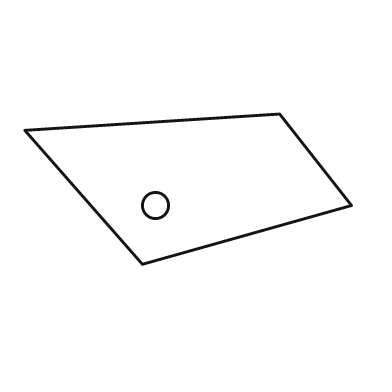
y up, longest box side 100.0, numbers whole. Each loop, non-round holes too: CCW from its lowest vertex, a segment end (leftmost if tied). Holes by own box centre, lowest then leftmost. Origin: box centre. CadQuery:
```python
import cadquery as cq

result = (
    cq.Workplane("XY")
    .moveTo(-14.0, -23.0)
    .lineTo(50.0, -5.0)
    .lineTo(28.0, 23.0)
    .lineTo(-50.0, 18.0)
    .close()
    .moveTo(-10.0, -5.0)
    .circle(4.0)
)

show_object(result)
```